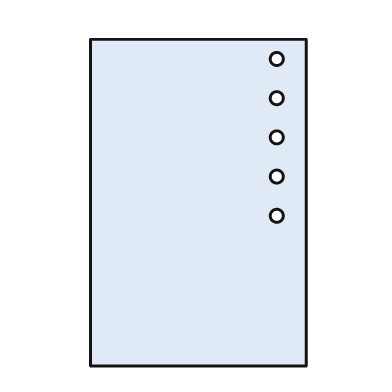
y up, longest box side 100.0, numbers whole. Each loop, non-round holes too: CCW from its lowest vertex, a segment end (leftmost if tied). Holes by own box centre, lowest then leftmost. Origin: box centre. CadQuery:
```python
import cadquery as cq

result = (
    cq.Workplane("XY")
    .moveTo(-33.0, -50.0)
    .lineTo(33.0, -50.0)
    .lineTo(33.0, 50.0)
    .lineTo(-33.0, 50.0)
    .close()
    .moveTo(24.0, -4.0)
    .circle(2.0)
    .moveTo(24.0, 8.0)
    .circle(2.0)
    .moveTo(24.0, 20.0)
    .circle(2.0)
    .moveTo(24.0, 32.0)
    .circle(2.0)
    .moveTo(24.0, 44.0)
    .circle(2.0)
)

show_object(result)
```